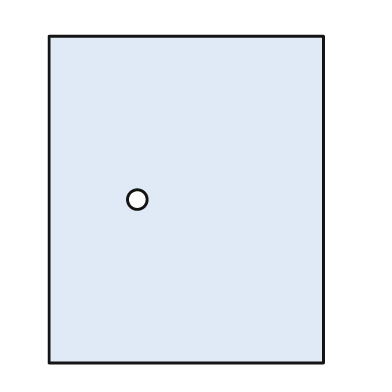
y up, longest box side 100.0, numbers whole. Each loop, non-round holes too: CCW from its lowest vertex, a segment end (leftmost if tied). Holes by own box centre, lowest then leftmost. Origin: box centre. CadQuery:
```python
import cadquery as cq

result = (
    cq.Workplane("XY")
    .moveTo(-42.0, -50.0)
    .lineTo(42.0, -50.0)
    .lineTo(42.0, 50.0)
    .lineTo(-42.0, 50.0)
    .close()
    .moveTo(-15.0, 0.0)
    .circle(3.0)
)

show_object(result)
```